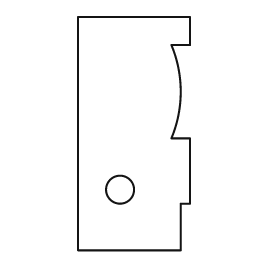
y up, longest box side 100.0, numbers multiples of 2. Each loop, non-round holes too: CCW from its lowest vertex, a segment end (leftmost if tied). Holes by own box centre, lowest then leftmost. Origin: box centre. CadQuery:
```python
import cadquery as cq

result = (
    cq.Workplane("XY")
    .moveTo(-24.0, -50.0)
    .lineTo(20.0, -50.0)
    .lineTo(20.0, -30.0)
    .lineTo(24.0, -30.0)
    .lineTo(24.0, -2.0)
    .lineTo(16.0, -2.0)
    .threePointArc((20.0, 18.0), (16.0, 38.0))
    .lineTo(24.0, 38.0)
    .lineTo(24.0, 50.0)
    .lineTo(-24.0, 50.0)
    .close()
    .moveTo(-6.0, -24.0)
    .circle(6.0)
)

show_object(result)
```